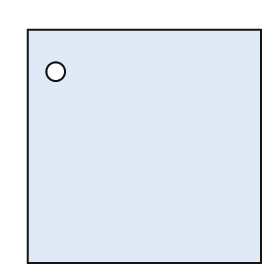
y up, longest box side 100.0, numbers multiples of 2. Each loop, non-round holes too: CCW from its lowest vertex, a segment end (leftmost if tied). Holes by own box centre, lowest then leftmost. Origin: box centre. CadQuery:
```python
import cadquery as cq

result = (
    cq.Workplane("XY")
    .moveTo(-50.0, -50.0)
    .lineTo(50.0, -50.0)
    .lineTo(50.0, 50.0)
    .lineTo(-50.0, 50.0)
    .close()
    .moveTo(-38.0, 32.0)
    .circle(4.0)
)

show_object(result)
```